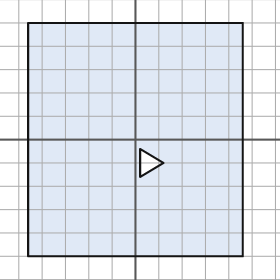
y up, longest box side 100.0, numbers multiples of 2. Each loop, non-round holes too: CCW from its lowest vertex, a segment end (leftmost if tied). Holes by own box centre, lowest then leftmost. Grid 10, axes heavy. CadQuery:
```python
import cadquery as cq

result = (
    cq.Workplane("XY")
    .moveTo(-46.0, -50.0)
    .lineTo(46.0, -50.0)
    .lineTo(46.0, 50.0)
    .lineTo(-46.0, 50.0)
    .close()
    .moveTo(2.0, -16.0)
    .lineTo(12.0, -10.0)
    .lineTo(2.0, -4.0)
    .close()
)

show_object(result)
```